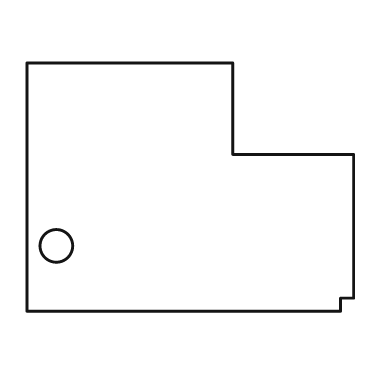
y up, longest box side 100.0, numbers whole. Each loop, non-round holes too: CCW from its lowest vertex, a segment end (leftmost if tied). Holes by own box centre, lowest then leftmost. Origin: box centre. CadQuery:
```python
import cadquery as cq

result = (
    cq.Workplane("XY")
    .moveTo(-50.0, -38.0)
    .lineTo(46.0, -38.0)
    .lineTo(46.0, -34.0)
    .lineTo(50.0, -34.0)
    .lineTo(50.0, 10.0)
    .lineTo(13.0, 10.0)
    .lineTo(13.0, 38.0)
    .lineTo(-50.0, 38.0)
    .close()
    .moveTo(-41.0, -18.0)
    .circle(5.0)
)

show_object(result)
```